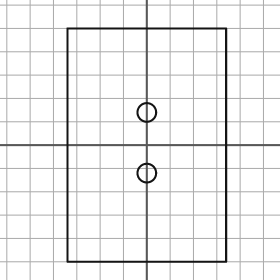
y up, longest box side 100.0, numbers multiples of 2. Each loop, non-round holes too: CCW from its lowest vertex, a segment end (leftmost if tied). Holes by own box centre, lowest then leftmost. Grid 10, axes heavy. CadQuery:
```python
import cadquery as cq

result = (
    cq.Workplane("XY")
    .moveTo(-34.0, -50.0)
    .lineTo(34.0, -50.0)
    .lineTo(34.0, 50.0)
    .lineTo(-34.0, 50.0)
    .close()
    .moveTo(0.0, -12.0)
    .circle(4.0)
    .moveTo(0.0, 14.0)
    .circle(4.0)
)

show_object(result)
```